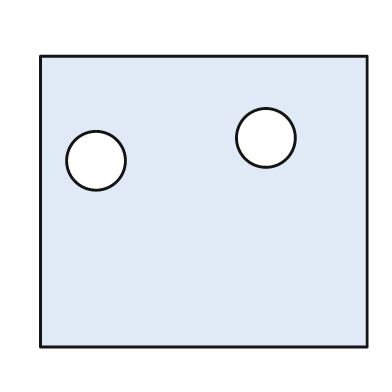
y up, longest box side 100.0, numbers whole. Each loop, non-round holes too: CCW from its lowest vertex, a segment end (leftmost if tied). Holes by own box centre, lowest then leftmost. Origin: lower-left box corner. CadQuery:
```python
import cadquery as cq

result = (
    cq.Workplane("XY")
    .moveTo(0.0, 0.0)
    .lineTo(100.0, 0.0)
    .lineTo(100.0, 89.0)
    .lineTo(0.0, 89.0)
    .close()
    .moveTo(17.0, 57.0)
    .circle(9.0)
    .moveTo(69.0, 64.0)
    .circle(9.0)
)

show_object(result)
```